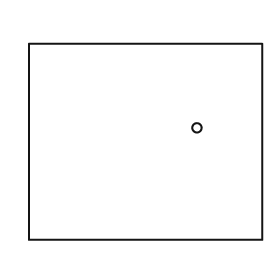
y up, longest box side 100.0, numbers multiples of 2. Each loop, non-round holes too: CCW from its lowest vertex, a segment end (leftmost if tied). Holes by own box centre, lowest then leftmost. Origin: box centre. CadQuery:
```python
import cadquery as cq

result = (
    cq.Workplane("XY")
    .moveTo(-50.0, -42.0)
    .lineTo(50.0, -42.0)
    .lineTo(50.0, 42.0)
    .lineTo(-50.0, 42.0)
    .close()
    .moveTo(22.0, 6.0)
    .circle(2.0)
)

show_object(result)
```